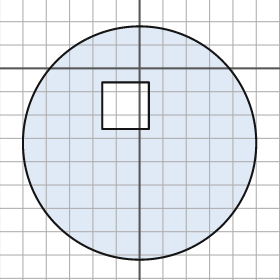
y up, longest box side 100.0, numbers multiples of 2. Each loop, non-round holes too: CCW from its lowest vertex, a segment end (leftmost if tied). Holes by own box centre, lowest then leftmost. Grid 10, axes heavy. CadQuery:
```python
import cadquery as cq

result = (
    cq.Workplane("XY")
    .moveTo(0.0, -32.0)
    .circle(50.0)
    .moveTo(-16.0, -26.0)
    .lineTo(4.0, -26.0)
    .lineTo(4.0, -6.0)
    .lineTo(-16.0, -6.0)
    .close()
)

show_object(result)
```